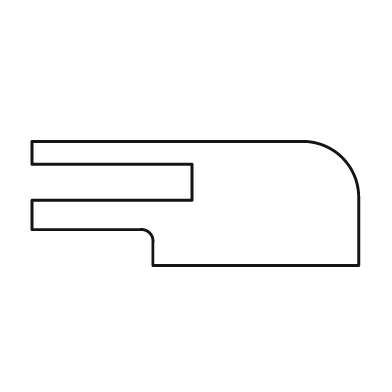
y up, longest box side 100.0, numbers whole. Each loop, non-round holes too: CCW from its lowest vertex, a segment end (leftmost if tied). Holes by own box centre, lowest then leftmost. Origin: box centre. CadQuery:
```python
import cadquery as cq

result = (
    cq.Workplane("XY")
    .moveTo(-13.0, -19.0)
    .lineTo(50.0, -19.0)
    .lineTo(50.0, 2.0)
    .threePointArc((45.0, 14.0), (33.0, 19.0))
    .lineTo(-50.0, 19.0)
    .lineTo(-50.0, 12.0)
    .lineTo(-1.0, 12.0)
    .lineTo(-1.0, 1.0)
    .lineTo(-50.0, 1.0)
    .lineTo(-50.0, -8.0)
    .lineTo(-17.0, -8.0)
    .threePointArc((-14.0, -9.0), (-13.0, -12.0))
    .close()
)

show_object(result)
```